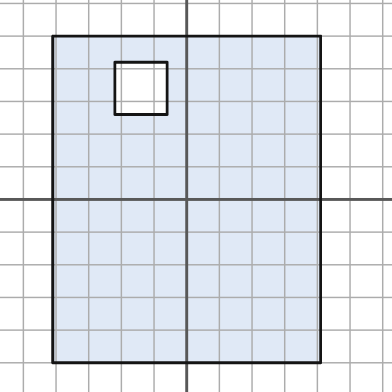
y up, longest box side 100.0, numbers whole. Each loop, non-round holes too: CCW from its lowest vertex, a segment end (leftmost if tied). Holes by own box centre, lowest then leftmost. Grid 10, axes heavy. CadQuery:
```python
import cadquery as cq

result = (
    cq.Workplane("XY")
    .moveTo(-41.0, -50.0)
    .lineTo(41.0, -50.0)
    .lineTo(41.0, 50.0)
    .lineTo(-41.0, 50.0)
    .close()
    .moveTo(-22.0, 26.0)
    .lineTo(-6.0, 26.0)
    .lineTo(-6.0, 42.0)
    .lineTo(-22.0, 42.0)
    .close()
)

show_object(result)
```